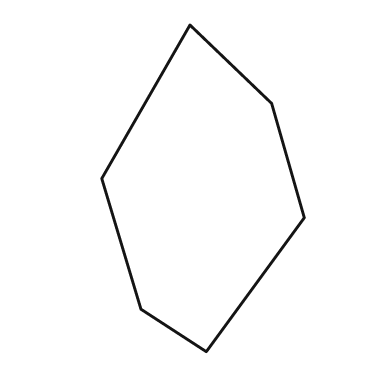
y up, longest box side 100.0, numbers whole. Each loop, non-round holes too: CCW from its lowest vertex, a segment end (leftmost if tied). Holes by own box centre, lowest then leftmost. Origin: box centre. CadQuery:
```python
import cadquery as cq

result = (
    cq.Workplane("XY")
    .moveTo(1.0, -50.0)
    .lineTo(31.0, -9.0)
    .lineTo(21.0, 26.0)
    .lineTo(-4.0, 50.0)
    .lineTo(-31.0, 3.0)
    .lineTo(-19.0, -37.0)
    .close()
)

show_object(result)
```